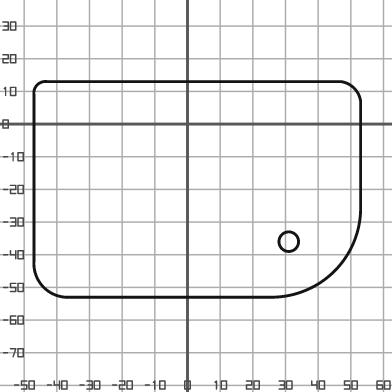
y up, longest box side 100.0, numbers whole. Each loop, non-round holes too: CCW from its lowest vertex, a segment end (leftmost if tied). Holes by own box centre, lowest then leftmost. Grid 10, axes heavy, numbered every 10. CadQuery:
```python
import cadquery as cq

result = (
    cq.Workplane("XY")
    .moveTo(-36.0, -53.0)
    .lineTo(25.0, -53.0)
    .threePointArc((45.0, -45.0), (53.0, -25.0))
    .lineTo(53.0, 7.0)
    .threePointArc((51.0, 11.0), (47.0, 13.0))
    .lineTo(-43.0, 13.0)
    .threePointArc((-46.0, 12.0), (-47.0, 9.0))
    .lineTo(-47.0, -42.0)
    .threePointArc((-44.0, -50.0), (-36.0, -53.0))
    .close()
    .moveTo(31.0, -36.0)
    .circle(3.0)
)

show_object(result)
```